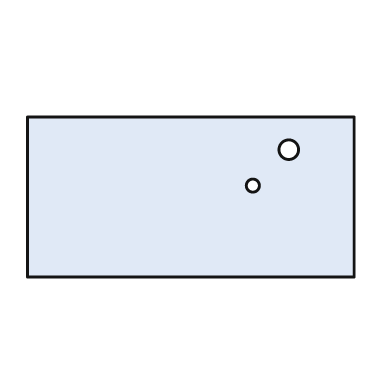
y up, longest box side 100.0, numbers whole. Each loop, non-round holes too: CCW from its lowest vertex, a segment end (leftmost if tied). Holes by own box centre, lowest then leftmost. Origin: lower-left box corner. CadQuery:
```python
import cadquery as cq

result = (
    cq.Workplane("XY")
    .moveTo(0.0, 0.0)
    .lineTo(100.0, 0.0)
    .lineTo(100.0, 49.0)
    .lineTo(0.0, 49.0)
    .close()
    .moveTo(69.0, 28.0)
    .circle(2.0)
    .moveTo(80.0, 39.0)
    .circle(3.0)
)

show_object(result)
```